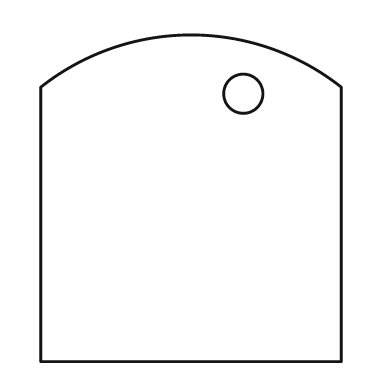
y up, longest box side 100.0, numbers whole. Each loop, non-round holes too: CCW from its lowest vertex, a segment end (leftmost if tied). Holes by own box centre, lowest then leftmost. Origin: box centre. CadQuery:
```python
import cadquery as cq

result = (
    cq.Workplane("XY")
    .moveTo(-46.0, -50.0)
    .lineTo(46.0, -50.0)
    .lineTo(46.0, 34.0)
    .threePointArc((0.0, 50.0), (-46.0, 34.0))
    .close()
    .moveTo(16.0, 32.0)
    .circle(6.0)
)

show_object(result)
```